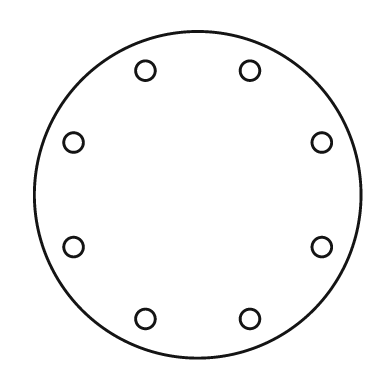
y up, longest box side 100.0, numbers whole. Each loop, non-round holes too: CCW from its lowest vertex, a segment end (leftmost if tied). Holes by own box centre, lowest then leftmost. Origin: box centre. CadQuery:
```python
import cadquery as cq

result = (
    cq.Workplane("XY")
    .moveTo(0.0, 0.0)
    .circle(50.0)
    .moveTo(-16.0, -38.0)
    .circle(3.0)
    .moveTo(16.0, -38.0)
    .circle(3.0)
    .moveTo(-38.0, -16.0)
    .circle(3.0)
    .moveTo(38.0, -16.0)
    .circle(3.0)
    .moveTo(-38.0, 16.0)
    .circle(3.0)
    .moveTo(38.0, 16.0)
    .circle(3.0)
    .moveTo(-16.0, 38.0)
    .circle(3.0)
    .moveTo(16.0, 38.0)
    .circle(3.0)
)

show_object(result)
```